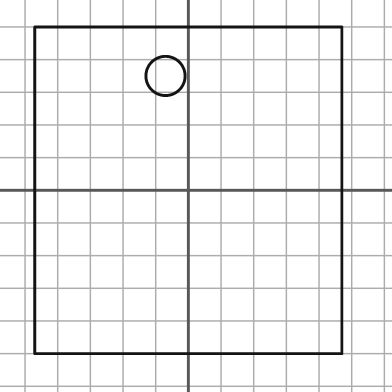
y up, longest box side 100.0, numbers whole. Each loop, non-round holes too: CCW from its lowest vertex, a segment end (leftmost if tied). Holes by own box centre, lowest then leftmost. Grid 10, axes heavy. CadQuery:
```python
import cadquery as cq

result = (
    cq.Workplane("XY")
    .moveTo(-47.0, -50.0)
    .lineTo(47.0, -50.0)
    .lineTo(47.0, 50.0)
    .lineTo(-47.0, 50.0)
    .close()
    .moveTo(-7.0, 35.0)
    .circle(6.0)
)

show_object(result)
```